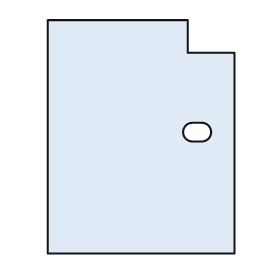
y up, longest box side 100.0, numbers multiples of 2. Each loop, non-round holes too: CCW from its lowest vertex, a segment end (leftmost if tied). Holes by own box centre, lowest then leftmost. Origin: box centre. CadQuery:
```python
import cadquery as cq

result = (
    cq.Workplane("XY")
    .moveTo(-40.0, -50.0)
    .lineTo(40.0, -50.0)
    .lineTo(40.0, 36.0)
    .lineTo(20.0, 36.0)
    .lineTo(20.0, 50.0)
    .lineTo(-40.0, 50.0)
    .close()
    .moveTo(22.0, -2.0)
    .lineTo(26.0, -2.0)
    .threePointArc((30.0, 2.0), (26.0, 6.0))
    .lineTo(22.0, 6.0)
    .threePointArc((18.0, 2.0), (22.0, -2.0))
    .close()
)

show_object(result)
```